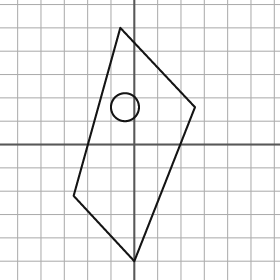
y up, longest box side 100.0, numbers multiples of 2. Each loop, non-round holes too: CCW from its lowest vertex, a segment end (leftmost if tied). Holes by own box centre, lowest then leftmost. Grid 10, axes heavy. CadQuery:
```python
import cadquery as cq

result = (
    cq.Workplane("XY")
    .moveTo(0.0, -50.0)
    .lineTo(26.0, 16.0)
    .lineTo(-6.0, 50.0)
    .lineTo(-26.0, -22.0)
    .close()
    .moveTo(-4.0, 16.0)
    .circle(6.0)
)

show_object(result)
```